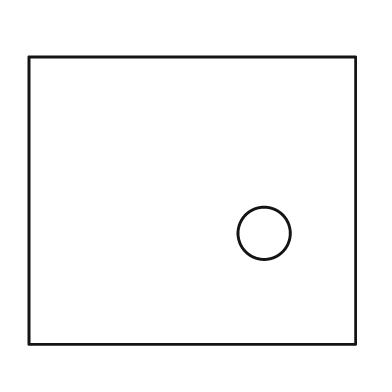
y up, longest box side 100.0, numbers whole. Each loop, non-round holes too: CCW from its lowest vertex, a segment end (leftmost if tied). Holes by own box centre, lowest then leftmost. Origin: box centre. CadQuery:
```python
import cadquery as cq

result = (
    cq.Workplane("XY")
    .moveTo(-50.0, -44.0)
    .lineTo(50.0, -44.0)
    .lineTo(50.0, 44.0)
    .lineTo(-50.0, 44.0)
    .close()
    .moveTo(22.0, -10.0)
    .circle(8.0)
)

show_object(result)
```